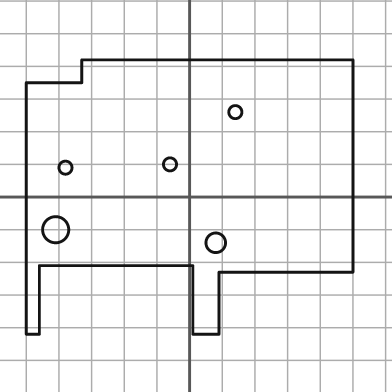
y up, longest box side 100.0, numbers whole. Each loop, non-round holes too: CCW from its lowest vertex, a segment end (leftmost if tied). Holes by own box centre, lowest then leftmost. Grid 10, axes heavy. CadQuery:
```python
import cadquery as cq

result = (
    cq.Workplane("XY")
    .moveTo(-50.0, -42.0)
    .lineTo(-46.0, -42.0)
    .lineTo(-46.0, -21.0)
    .lineTo(1.0, -21.0)
    .lineTo(1.0, -42.0)
    .lineTo(9.0, -42.0)
    .lineTo(9.0, -23.0)
    .lineTo(50.0, -23.0)
    .lineTo(50.0, 42.0)
    .lineTo(-33.0, 42.0)
    .lineTo(-33.0, 35.0)
    .lineTo(-50.0, 35.0)
    .close()
    .moveTo(8.0, -14.0)
    .circle(3.0)
    .moveTo(-41.0, -10.0)
    .circle(4.0)
    .moveTo(-38.0, 9.0)
    .circle(2.0)
    .moveTo(-6.0, 10.0)
    .circle(2.0)
    .moveTo(14.0, 26.0)
    .circle(2.0)
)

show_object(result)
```